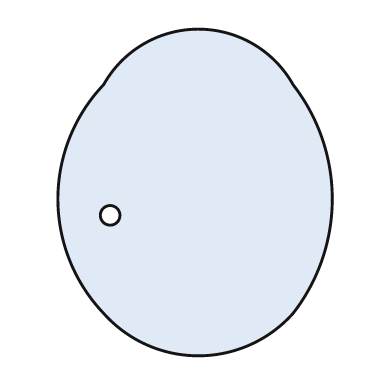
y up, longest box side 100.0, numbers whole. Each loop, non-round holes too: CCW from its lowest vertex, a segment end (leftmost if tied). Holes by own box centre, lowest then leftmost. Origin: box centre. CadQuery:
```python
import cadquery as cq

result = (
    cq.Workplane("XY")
    .moveTo(-28.0, -37.0)
    .threePointArc((1.0, -50.0), (30.0, -37.0))
    .threePointArc((42.0, -2.0), (30.0, 33.0))
    .threePointArc((1.0, 50.0), (-28.0, 33.0))
    .threePointArc((-42.0, -2.0), (-28.0, -37.0))
    .close()
    .moveTo(-26.0, -7.0)
    .circle(3.0)
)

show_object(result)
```